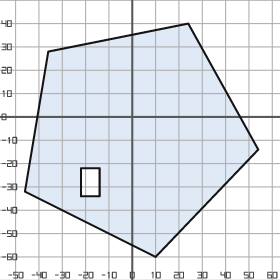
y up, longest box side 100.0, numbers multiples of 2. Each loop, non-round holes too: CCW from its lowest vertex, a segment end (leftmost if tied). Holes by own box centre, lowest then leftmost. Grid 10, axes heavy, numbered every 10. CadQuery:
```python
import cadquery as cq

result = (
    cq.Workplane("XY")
    .moveTo(10.0, -60.0)
    .lineTo(54.0, -14.0)
    .lineTo(24.0, 40.0)
    .lineTo(-36.0, 28.0)
    .lineTo(-46.0, -32.0)
    .close()
    .moveTo(-22.0, -34.0)
    .lineTo(-14.0, -34.0)
    .lineTo(-14.0, -22.0)
    .lineTo(-22.0, -22.0)
    .close()
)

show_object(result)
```